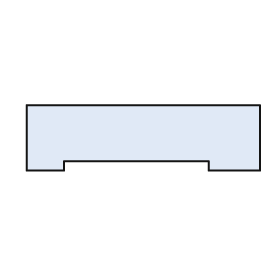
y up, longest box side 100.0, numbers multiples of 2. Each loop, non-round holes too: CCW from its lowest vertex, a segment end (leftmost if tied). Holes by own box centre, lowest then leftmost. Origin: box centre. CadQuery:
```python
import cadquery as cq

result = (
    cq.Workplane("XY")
    .moveTo(-50.0, -14.0)
    .lineTo(-34.0, -14.0)
    .lineTo(-34.0, -10.0)
    .lineTo(28.0, -10.0)
    .lineTo(28.0, -14.0)
    .lineTo(50.0, -14.0)
    .lineTo(50.0, 14.0)
    .lineTo(-50.0, 14.0)
    .close()
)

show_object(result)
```